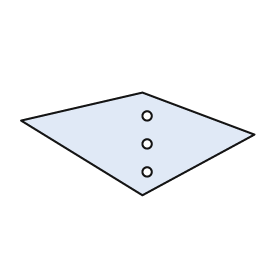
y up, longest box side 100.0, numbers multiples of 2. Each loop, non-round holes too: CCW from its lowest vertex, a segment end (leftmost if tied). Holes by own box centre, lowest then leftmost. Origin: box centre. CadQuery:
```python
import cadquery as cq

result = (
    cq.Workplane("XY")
    .moveTo(2.0, -22.0)
    .lineTo(50.0, 4.0)
    .lineTo(2.0, 22.0)
    .lineTo(-50.0, 10.0)
    .close()
    .moveTo(4.0, -12.0)
    .circle(2.0)
    .moveTo(4.0, 0.0)
    .circle(2.0)
    .moveTo(4.0, 12.0)
    .circle(2.0)
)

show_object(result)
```